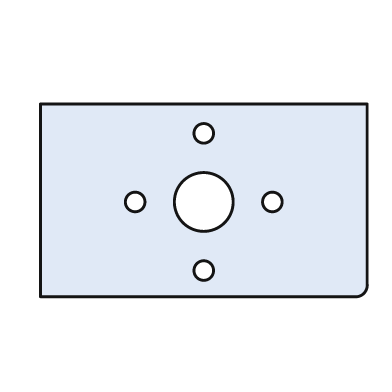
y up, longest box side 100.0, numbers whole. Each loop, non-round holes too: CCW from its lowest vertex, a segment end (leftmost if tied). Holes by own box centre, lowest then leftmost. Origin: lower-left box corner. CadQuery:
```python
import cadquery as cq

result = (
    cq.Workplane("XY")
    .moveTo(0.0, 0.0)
    .lineTo(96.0, 0.0)
    .threePointArc((99.0, 1.0), (100.0, 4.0))
    .lineTo(100.0, 59.0)
    .lineTo(0.0, 59.0)
    .close()
    .moveTo(50.0, 8.0)
    .circle(3.0)
    .moveTo(29.0, 29.0)
    .circle(3.0)
    .moveTo(50.0, 29.0)
    .circle(9.0)
    .moveTo(71.0, 29.0)
    .circle(3.0)
    .moveTo(50.0, 50.0)
    .circle(3.0)
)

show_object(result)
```